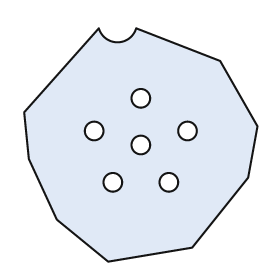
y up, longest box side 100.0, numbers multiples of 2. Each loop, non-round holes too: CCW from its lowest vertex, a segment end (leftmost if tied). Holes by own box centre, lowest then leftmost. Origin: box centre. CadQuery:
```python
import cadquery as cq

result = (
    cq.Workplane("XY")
    .moveTo(-14.0, -50.0)
    .lineTo(22.0, -44.0)
    .lineTo(46.0, -14.0)
    .lineTo(50.0, 8.0)
    .lineTo(34.0, 36.0)
    .lineTo(-2.0, 50.0)
    .threePointArc((-10.0, 44.0), (-18.0, 50.0))
    .lineTo(-50.0, 14.0)
    .lineTo(-48.0, -6.0)
    .lineTo(-36.0, -32.0)
    .close()
    .moveTo(-12.0, -16.0)
    .circle(4.0)
    .moveTo(12.0, -16.0)
    .circle(4.0)
    .moveTo(0.0, 0.0)
    .circle(4.0)
    .moveTo(-20.0, 6.0)
    .circle(4.0)
    .moveTo(20.0, 6.0)
    .circle(4.0)
    .moveTo(0.0, 20.0)
    .circle(4.0)
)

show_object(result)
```